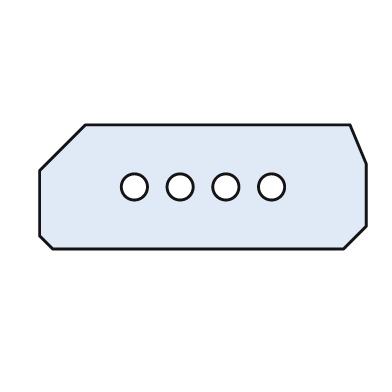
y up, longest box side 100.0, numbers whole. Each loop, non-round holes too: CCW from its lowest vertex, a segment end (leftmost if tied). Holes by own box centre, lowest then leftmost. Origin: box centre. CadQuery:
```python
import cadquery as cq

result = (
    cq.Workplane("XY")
    .moveTo(-46.0, -19.0)
    .lineTo(43.0, -19.0)
    .lineTo(50.0, -12.0)
    .lineTo(50.0, 7.0)
    .lineTo(45.0, 19.0)
    .lineTo(-36.0, 19.0)
    .lineTo(-50.0, 5.0)
    .lineTo(-50.0, -15.0)
    .close()
    .moveTo(-21.0, 0.0)
    .circle(4.0)
    .moveTo(-7.0, 0.0)
    .circle(4.0)
    .moveTo(7.0, 0.0)
    .circle(4.0)
    .moveTo(21.0, 0.0)
    .circle(4.0)
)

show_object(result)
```